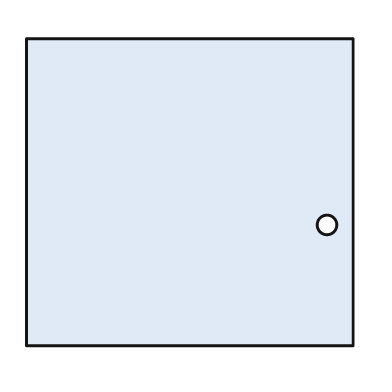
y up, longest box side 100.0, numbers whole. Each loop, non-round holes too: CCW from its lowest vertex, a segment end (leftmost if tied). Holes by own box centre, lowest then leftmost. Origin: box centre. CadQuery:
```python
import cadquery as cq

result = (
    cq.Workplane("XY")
    .moveTo(-50.0, -47.0)
    .lineTo(50.0, -47.0)
    .lineTo(50.0, 47.0)
    .lineTo(-50.0, 47.0)
    .close()
    .moveTo(42.0, -10.0)
    .circle(3.0)
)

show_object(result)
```